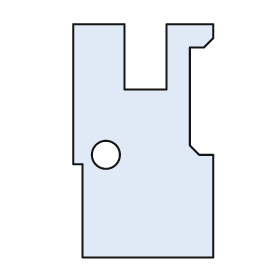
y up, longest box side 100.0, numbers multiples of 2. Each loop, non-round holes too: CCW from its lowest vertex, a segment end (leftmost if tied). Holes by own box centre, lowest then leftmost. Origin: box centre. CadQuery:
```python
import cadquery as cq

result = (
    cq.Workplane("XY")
    .moveTo(-26.0, -50.0)
    .lineTo(30.0, -50.0)
    .lineTo(30.0, -6.0)
    .lineTo(24.0, -6.0)
    .lineTo(20.0, -2.0)
    .lineTo(20.0, 40.0)
    .lineTo(26.0, 40.0)
    .lineTo(30.0, 44.0)
    .lineTo(30.0, 50.0)
    .lineTo(10.0, 50.0)
    .lineTo(10.0, 22.0)
    .lineTo(-8.0, 22.0)
    .lineTo(-8.0, 50.0)
    .lineTo(-30.0, 50.0)
    .lineTo(-30.0, -10.0)
    .lineTo(-26.0, -10.0)
    .close()
    .moveTo(-16.0, -6.0)
    .circle(6.0)
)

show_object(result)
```